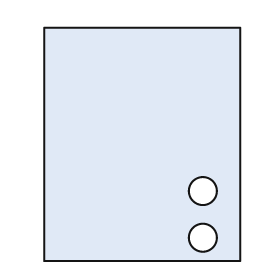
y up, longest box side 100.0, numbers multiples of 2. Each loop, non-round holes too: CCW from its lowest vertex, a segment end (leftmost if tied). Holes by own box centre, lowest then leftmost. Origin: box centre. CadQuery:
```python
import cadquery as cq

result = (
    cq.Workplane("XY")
    .moveTo(-42.0, -50.0)
    .lineTo(42.0, -50.0)
    .lineTo(42.0, 50.0)
    .lineTo(-42.0, 50.0)
    .close()
    .moveTo(26.0, -40.0)
    .circle(6.0)
    .moveTo(26.0, -20.0)
    .circle(6.0)
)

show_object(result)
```